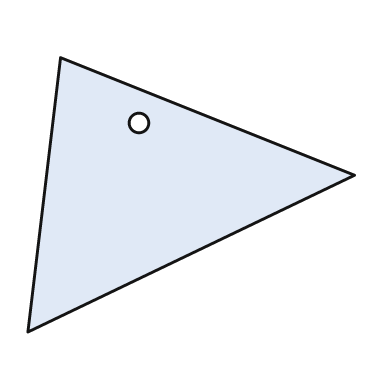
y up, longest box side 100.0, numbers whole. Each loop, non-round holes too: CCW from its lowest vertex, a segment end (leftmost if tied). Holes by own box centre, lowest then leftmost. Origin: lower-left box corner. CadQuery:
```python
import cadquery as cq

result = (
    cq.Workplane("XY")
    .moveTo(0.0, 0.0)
    .lineTo(100.0, 48.0)
    .lineTo(10.0, 84.0)
    .close()
    .moveTo(34.0, 64.0)
    .circle(3.0)
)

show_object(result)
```